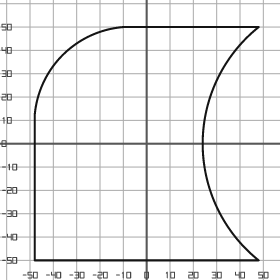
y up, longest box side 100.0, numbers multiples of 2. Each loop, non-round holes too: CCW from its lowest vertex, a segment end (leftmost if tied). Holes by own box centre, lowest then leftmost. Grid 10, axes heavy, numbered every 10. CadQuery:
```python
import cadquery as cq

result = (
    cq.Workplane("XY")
    .moveTo(-48.0, -50.0)
    .lineTo(48.0, -50.0)
    .threePointArc((24.0, 0.0), (48.0, 50.0))
    .lineTo(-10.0, 50.0)
    .threePointArc((-36.0, 38.0), (-48.0, 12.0))
    .close()
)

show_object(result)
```